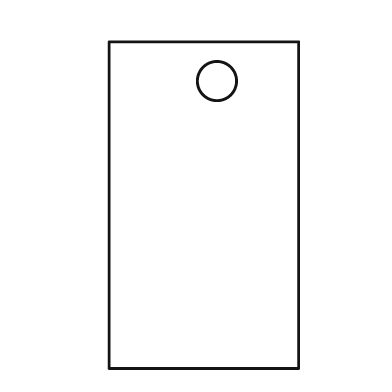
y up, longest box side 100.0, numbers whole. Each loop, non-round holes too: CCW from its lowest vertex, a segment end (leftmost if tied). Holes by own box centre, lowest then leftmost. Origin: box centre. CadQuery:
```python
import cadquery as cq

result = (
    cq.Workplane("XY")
    .moveTo(-29.0, -50.0)
    .lineTo(29.0, -50.0)
    .lineTo(29.0, 50.0)
    .lineTo(-29.0, 50.0)
    .close()
    .moveTo(4.0, 38.0)
    .circle(6.0)
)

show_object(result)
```